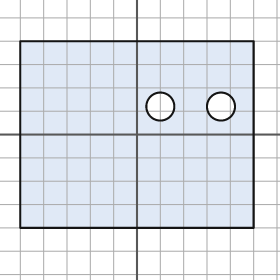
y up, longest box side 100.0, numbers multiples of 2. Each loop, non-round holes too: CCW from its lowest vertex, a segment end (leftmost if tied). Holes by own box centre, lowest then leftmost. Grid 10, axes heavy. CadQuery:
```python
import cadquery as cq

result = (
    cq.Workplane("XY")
    .moveTo(-50.0, -40.0)
    .lineTo(50.0, -40.0)
    .lineTo(50.0, 40.0)
    .lineTo(-50.0, 40.0)
    .close()
    .moveTo(10.0, 12.0)
    .circle(6.0)
    .moveTo(36.0, 12.0)
    .circle(6.0)
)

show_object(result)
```